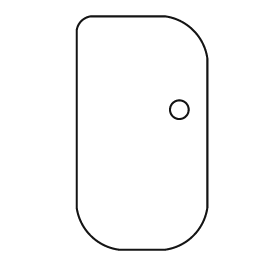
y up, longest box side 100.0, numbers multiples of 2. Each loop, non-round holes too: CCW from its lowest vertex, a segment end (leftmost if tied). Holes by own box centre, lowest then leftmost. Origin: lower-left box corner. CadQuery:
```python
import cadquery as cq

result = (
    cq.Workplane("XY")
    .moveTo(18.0, 0.0)
    .lineTo(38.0, 0.0)
    .threePointArc((50.0, 6.0), (56.0, 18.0))
    .lineTo(56.0, 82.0)
    .threePointArc((50.0, 94.0), (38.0, 100.0))
    .lineTo(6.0, 100.0)
    .threePointArc((2.0, 98.0), (0.0, 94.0))
    .lineTo(0.0, 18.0)
    .threePointArc((6.0, 6.0), (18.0, 0.0))
    .close()
    .moveTo(44.0, 60.0)
    .circle(4.0)
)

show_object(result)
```